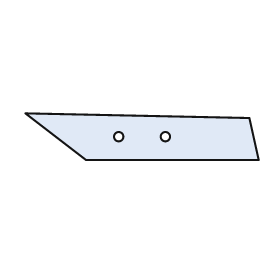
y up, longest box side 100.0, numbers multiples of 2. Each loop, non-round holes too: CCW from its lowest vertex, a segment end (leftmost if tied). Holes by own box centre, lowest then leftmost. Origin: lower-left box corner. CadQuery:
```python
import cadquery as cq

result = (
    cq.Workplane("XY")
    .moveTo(26.0, 0.0)
    .lineTo(100.0, 0.0)
    .lineTo(96.0, 18.0)
    .lineTo(0.0, 20.0)
    .close()
    .moveTo(40.0, 10.0)
    .circle(2.0)
    .moveTo(60.0, 10.0)
    .circle(2.0)
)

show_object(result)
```